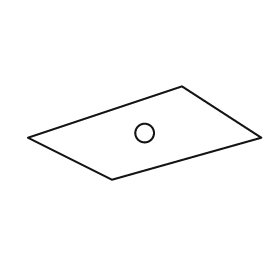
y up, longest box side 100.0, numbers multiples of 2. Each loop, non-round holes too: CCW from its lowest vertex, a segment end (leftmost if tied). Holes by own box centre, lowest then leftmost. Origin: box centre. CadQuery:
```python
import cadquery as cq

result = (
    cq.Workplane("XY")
    .moveTo(-14.0, -20.0)
    .lineTo(50.0, -2.0)
    .lineTo(16.0, 20.0)
    .lineTo(-50.0, -2.0)
    .close()
    .moveTo(0.0, 0.0)
    .circle(4.0)
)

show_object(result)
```